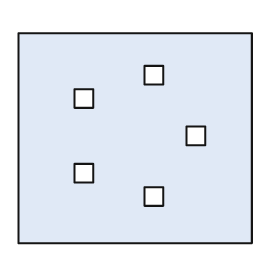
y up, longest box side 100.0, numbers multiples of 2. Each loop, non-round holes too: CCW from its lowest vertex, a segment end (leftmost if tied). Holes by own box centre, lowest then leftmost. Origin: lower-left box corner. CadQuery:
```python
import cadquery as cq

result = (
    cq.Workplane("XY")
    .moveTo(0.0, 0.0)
    .lineTo(100.0, 0.0)
    .lineTo(100.0, 90.0)
    .lineTo(0.0, 90.0)
    .close()
    .moveTo(54.0, 16.0)
    .lineTo(62.0, 16.0)
    .lineTo(62.0, 24.0)
    .lineTo(54.0, 24.0)
    .close()
    .moveTo(24.0, 26.0)
    .lineTo(32.0, 26.0)
    .lineTo(32.0, 34.0)
    .lineTo(24.0, 34.0)
    .close()
    .moveTo(72.0, 42.0)
    .lineTo(80.0, 42.0)
    .lineTo(80.0, 50.0)
    .lineTo(72.0, 50.0)
    .close()
    .moveTo(24.0, 58.0)
    .lineTo(32.0, 58.0)
    .lineTo(32.0, 66.0)
    .lineTo(24.0, 66.0)
    .close()
    .moveTo(54.0, 68.0)
    .lineTo(62.0, 68.0)
    .lineTo(62.0, 76.0)
    .lineTo(54.0, 76.0)
    .close()
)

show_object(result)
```